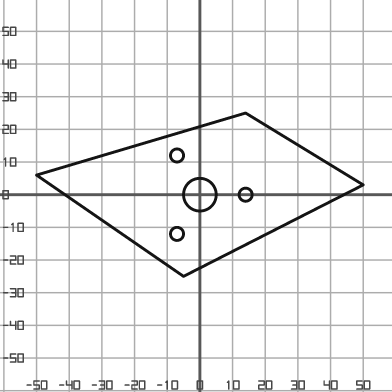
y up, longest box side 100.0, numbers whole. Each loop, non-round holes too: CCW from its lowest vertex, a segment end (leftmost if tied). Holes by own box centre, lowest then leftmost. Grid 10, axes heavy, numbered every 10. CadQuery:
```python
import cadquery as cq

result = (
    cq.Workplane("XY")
    .moveTo(-5.0, -25.0)
    .lineTo(50.0, 3.0)
    .lineTo(14.0, 25.0)
    .lineTo(-50.0, 6.0)
    .close()
    .moveTo(-7.0, -12.0)
    .circle(2.0)
    .moveTo(0.0, 0.0)
    .circle(5.0)
    .moveTo(14.0, 0.0)
    .circle(2.0)
    .moveTo(-7.0, 12.0)
    .circle(2.0)
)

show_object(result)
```